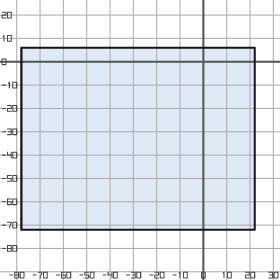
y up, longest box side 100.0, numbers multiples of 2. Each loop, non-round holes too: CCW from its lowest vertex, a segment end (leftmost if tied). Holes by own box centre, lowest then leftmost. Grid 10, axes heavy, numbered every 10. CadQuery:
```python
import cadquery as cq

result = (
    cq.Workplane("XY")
    .moveTo(-78.0, -72.0)
    .lineTo(22.0, -72.0)
    .lineTo(22.0, 6.0)
    .lineTo(-78.0, 6.0)
    .close()
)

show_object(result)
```